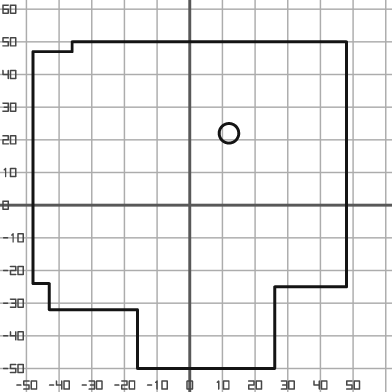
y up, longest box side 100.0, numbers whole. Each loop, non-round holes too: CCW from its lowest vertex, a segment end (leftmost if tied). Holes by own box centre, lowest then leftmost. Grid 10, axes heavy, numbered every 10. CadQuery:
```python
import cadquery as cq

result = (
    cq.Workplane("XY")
    .moveTo(-16.0, -50.0)
    .lineTo(26.0, -50.0)
    .lineTo(26.0, -25.0)
    .lineTo(48.0, -25.0)
    .lineTo(48.0, 50.0)
    .lineTo(-36.0, 50.0)
    .lineTo(-36.0, 47.0)
    .lineTo(-48.0, 47.0)
    .lineTo(-48.0, -24.0)
    .lineTo(-43.0, -24.0)
    .lineTo(-43.0, -32.0)
    .lineTo(-16.0, -32.0)
    .close()
    .moveTo(12.0, 22.0)
    .circle(3.0)
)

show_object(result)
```